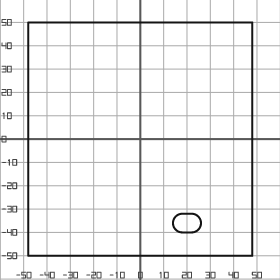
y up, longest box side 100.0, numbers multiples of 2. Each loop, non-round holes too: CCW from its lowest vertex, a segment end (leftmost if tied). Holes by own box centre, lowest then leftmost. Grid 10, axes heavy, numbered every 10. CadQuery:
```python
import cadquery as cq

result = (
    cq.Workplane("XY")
    .moveTo(-48.0, -50.0)
    .lineTo(48.0, -50.0)
    .lineTo(48.0, 50.0)
    .lineTo(-48.0, 50.0)
    .close()
    .moveTo(18.0, -40.0)
    .lineTo(22.0, -40.0)
    .threePointArc((26.0, -36.0), (22.0, -32.0))
    .lineTo(18.0, -32.0)
    .threePointArc((14.0, -36.0), (18.0, -40.0))
    .close()
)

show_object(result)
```